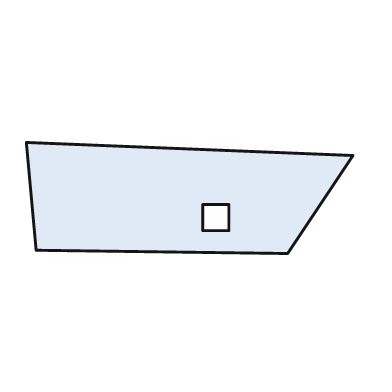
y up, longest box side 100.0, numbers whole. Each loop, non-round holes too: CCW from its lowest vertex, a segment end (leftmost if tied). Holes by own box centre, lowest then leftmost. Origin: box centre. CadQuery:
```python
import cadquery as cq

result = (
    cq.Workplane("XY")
    .moveTo(30.0, -17.0)
    .lineTo(50.0, 13.0)
    .lineTo(-50.0, 17.0)
    .lineTo(-47.0, -16.0)
    .close()
    .moveTo(4.0, -10.0)
    .lineTo(12.0, -10.0)
    .lineTo(12.0, -2.0)
    .lineTo(4.0, -2.0)
    .close()
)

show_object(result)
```